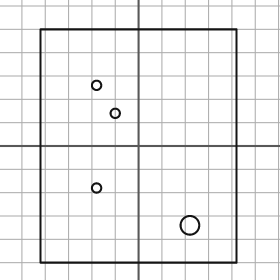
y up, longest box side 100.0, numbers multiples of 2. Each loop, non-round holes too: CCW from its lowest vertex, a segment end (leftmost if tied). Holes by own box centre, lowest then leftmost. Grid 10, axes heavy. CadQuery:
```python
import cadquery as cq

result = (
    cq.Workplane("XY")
    .moveTo(-42.0, -50.0)
    .lineTo(42.0, -50.0)
    .lineTo(42.0, 50.0)
    .lineTo(-42.0, 50.0)
    .close()
    .moveTo(22.0, -34.0)
    .circle(4.0)
    .moveTo(-18.0, -18.0)
    .circle(2.0)
    .moveTo(-10.0, 14.0)
    .circle(2.0)
    .moveTo(-18.0, 26.0)
    .circle(2.0)
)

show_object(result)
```